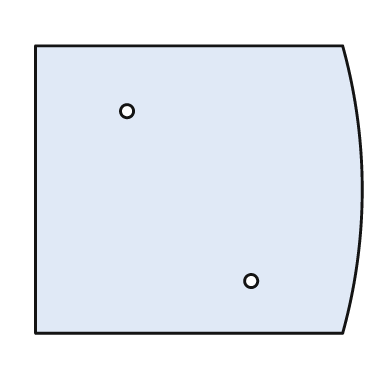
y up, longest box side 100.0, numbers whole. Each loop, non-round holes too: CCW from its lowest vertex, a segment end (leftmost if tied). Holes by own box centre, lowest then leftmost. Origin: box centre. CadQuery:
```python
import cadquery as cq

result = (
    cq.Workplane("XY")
    .moveTo(-50.0, -44.0)
    .lineTo(44.0, -44.0)
    .threePointArc((50.0, 0.0), (44.0, 44.0))
    .lineTo(-50.0, 44.0)
    .close()
    .moveTo(16.0, -28.0)
    .circle(2.0)
    .moveTo(-22.0, 24.0)
    .circle(2.0)
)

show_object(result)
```